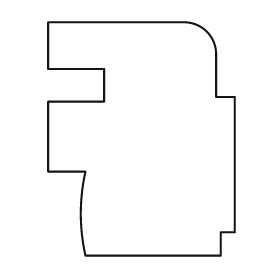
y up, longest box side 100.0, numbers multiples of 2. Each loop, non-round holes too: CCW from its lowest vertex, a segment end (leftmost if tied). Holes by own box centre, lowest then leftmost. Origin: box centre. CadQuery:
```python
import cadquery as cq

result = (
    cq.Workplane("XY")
    .moveTo(-24.0, -50.0)
    .lineTo(34.0, -50.0)
    .lineTo(34.0, -40.0)
    .lineTo(40.0, -40.0)
    .lineTo(40.0, 18.0)
    .lineTo(32.0, 18.0)
    .lineTo(32.0, 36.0)
    .threePointArc((28.0, 46.0), (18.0, 50.0))
    .lineTo(-40.0, 50.0)
    .lineTo(-40.0, 30.0)
    .lineTo(-16.0, 30.0)
    .lineTo(-16.0, 16.0)
    .lineTo(-40.0, 16.0)
    .lineTo(-40.0, -14.0)
    .lineTo(-24.0, -14.0)
    .threePointArc((-26.0, -32.0), (-24.0, -50.0))
    .close()
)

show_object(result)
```